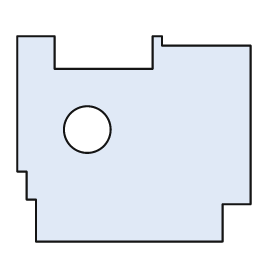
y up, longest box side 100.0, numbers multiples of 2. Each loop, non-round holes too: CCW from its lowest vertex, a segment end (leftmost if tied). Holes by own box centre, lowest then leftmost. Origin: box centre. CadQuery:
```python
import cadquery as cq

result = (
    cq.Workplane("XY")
    .moveTo(-42.0, -44.0)
    .lineTo(38.0, -44.0)
    .lineTo(38.0, -28.0)
    .lineTo(50.0, -28.0)
    .lineTo(50.0, 40.0)
    .lineTo(12.0, 40.0)
    .lineTo(12.0, 44.0)
    .lineTo(8.0, 44.0)
    .lineTo(8.0, 30.0)
    .lineTo(-34.0, 30.0)
    .lineTo(-34.0, 44.0)
    .lineTo(-50.0, 44.0)
    .lineTo(-50.0, -14.0)
    .lineTo(-46.0, -14.0)
    .lineTo(-46.0, -26.0)
    .lineTo(-42.0, -26.0)
    .close()
    .moveTo(-20.0, 4.0)
    .circle(10.0)
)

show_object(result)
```